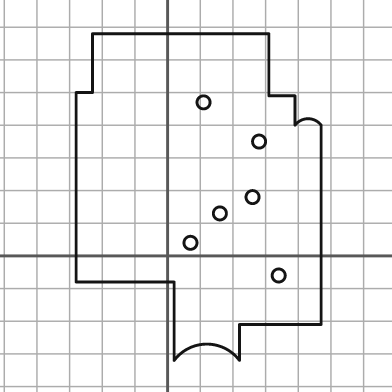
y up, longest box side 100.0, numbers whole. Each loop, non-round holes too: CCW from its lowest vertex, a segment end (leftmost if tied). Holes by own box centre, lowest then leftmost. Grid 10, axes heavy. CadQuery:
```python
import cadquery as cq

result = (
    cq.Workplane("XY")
    .moveTo(2.0, -32.0)
    .threePointArc((12.0, -27.0), (22.0, -32.0))
    .lineTo(22.0, -21.0)
    .lineTo(47.0, -21.0)
    .lineTo(47.0, 40.0)
    .threePointArc((43.0, 42.0), (39.0, 40.0))
    .lineTo(39.0, 49.0)
    .lineTo(31.0, 49.0)
    .lineTo(31.0, 68.0)
    .lineTo(-23.0, 68.0)
    .lineTo(-23.0, 50.0)
    .lineTo(-28.0, 50.0)
    .lineTo(-28.0, -8.0)
    .lineTo(2.0, -8.0)
    .close()
    .moveTo(34.0, -6.0)
    .circle(2.0)
    .moveTo(7.0, 4.0)
    .circle(2.0)
    .moveTo(16.0, 13.0)
    .circle(2.0)
    .moveTo(26.0, 18.0)
    .circle(2.0)
    .moveTo(28.0, 35.0)
    .circle(2.0)
    .moveTo(11.0, 47.0)
    .circle(2.0)
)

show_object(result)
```